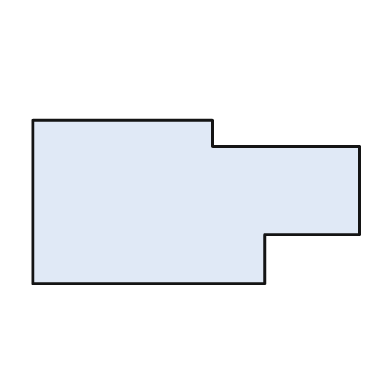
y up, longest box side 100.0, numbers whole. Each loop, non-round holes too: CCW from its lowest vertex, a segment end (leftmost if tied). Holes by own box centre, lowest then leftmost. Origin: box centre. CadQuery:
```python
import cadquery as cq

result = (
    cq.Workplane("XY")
    .moveTo(-50.0, -25.0)
    .lineTo(21.0, -25.0)
    .lineTo(21.0, -10.0)
    .lineTo(50.0, -10.0)
    .lineTo(50.0, 17.0)
    .lineTo(5.0, 17.0)
    .lineTo(5.0, 25.0)
    .lineTo(-50.0, 25.0)
    .close()
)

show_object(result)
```